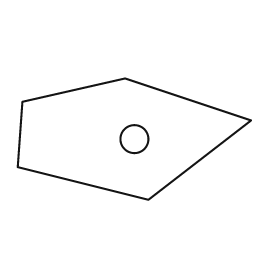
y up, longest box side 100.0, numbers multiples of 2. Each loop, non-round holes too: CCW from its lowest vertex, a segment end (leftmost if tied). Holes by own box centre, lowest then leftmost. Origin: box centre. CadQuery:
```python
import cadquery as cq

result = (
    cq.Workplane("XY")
    .moveTo(6.0, -26.0)
    .lineTo(50.0, 8.0)
    .lineTo(-4.0, 26.0)
    .lineTo(-48.0, 16.0)
    .lineTo(-50.0, -12.0)
    .close()
    .moveTo(0.0, 0.0)
    .circle(6.0)
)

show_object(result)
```